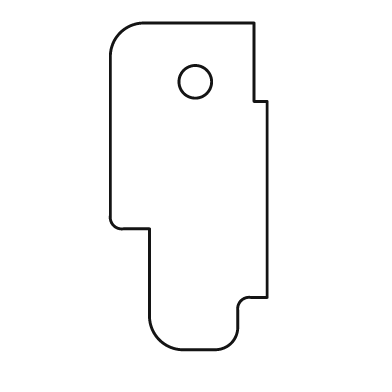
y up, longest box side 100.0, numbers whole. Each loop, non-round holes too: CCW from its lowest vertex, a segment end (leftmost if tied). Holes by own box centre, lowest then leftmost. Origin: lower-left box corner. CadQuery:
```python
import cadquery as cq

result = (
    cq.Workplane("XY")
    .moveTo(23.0, 0.0)
    .lineTo(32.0, 0.0)
    .threePointArc((37.0, 2.0), (39.0, 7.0))
    .lineTo(39.0, 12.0)
    .threePointArc((40.0, 15.0), (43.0, 16.0))
    .lineTo(48.0, 16.0)
    .lineTo(48.0, 76.0)
    .lineTo(44.0, 76.0)
    .lineTo(44.0, 100.0)
    .lineTo(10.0, 100.0)
    .threePointArc((3.0, 97.0), (0.0, 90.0))
    .lineTo(0.0, 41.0)
    .threePointArc((1.0, 38.0), (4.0, 37.0))
    .lineTo(12.0, 37.0)
    .lineTo(12.0, 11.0)
    .threePointArc((15.0, 3.0), (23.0, 0.0))
    .close()
    .moveTo(26.0, 82.0)
    .circle(5.0)
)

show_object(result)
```